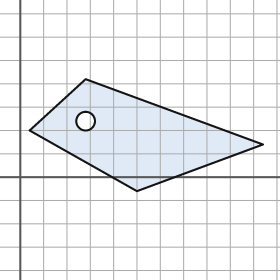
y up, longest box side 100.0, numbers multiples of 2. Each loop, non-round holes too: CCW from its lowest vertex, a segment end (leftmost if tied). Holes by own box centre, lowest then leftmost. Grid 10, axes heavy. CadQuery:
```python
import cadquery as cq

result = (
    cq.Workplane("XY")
    .moveTo(50.0, -6.0)
    .lineTo(104.0, 14.0)
    .lineTo(28.0, 42.0)
    .lineTo(4.0, 20.0)
    .close()
    .moveTo(28.0, 24.0)
    .circle(4.0)
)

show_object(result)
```